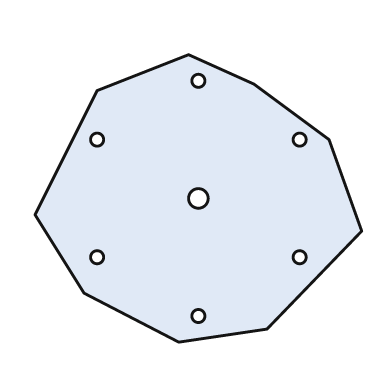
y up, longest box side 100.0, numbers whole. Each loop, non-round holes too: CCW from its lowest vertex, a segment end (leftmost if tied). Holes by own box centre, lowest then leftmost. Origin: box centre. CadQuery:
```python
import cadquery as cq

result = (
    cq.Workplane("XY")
    .moveTo(-6.0, -44.0)
    .lineTo(21.0, -40.0)
    .lineTo(50.0, -10.0)
    .lineTo(40.0, 18.0)
    .lineTo(17.0, 35.0)
    .lineTo(-3.0, 44.0)
    .lineTo(-31.0, 33.0)
    .lineTo(-50.0, -5.0)
    .lineTo(-35.0, -29.0)
    .close()
    .moveTo(0.0, -36.0)
    .circle(2.0)
    .moveTo(-31.0, -18.0)
    .circle(2.0)
    .moveTo(31.0, -18.0)
    .circle(2.0)
    .moveTo(0.0, 0.0)
    .circle(3.0)
    .moveTo(-31.0, 18.0)
    .circle(2.0)
    .moveTo(31.0, 18.0)
    .circle(2.0)
    .moveTo(0.0, 36.0)
    .circle(2.0)
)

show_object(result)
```